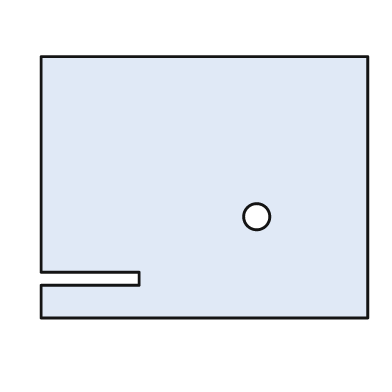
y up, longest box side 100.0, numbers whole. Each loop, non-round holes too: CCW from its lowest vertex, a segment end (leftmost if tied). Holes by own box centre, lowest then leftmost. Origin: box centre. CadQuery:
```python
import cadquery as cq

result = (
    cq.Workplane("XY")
    .moveTo(-50.0, -40.0)
    .lineTo(50.0, -40.0)
    .lineTo(50.0, 40.0)
    .lineTo(-50.0, 40.0)
    .lineTo(-50.0, -26.0)
    .lineTo(-20.0, -26.0)
    .lineTo(-20.0, -30.0)
    .lineTo(-50.0, -30.0)
    .close()
    .moveTo(16.0, -9.0)
    .circle(4.0)
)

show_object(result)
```